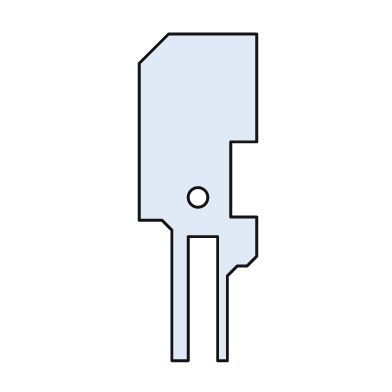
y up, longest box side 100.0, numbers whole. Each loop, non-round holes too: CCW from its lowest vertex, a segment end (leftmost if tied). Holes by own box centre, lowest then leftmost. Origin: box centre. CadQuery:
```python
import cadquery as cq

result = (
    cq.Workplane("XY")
    .moveTo(-8.0, -50.0)
    .lineTo(-3.0, -50.0)
    .lineTo(-3.0, -12.0)
    .lineTo(6.0, -12.0)
    .lineTo(6.0, -50.0)
    .lineTo(9.0, -50.0)
    .lineTo(9.0, -24.0)
    .lineTo(12.0, -21.0)
    .lineTo(15.0, -21.0)
    .lineTo(18.0, -18.0)
    .lineTo(18.0, -6.0)
    .lineTo(10.0, -6.0)
    .lineTo(10.0, 17.0)
    .lineTo(18.0, 17.0)
    .lineTo(18.0, 50.0)
    .lineTo(-9.0, 50.0)
    .lineTo(-18.0, 41.0)
    .lineTo(-18.0, -7.0)
    .lineTo(-11.0, -7.0)
    .lineTo(-8.0, -10.0)
    .close()
    .moveTo(0.0, 0.0)
    .circle(3.0)
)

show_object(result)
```